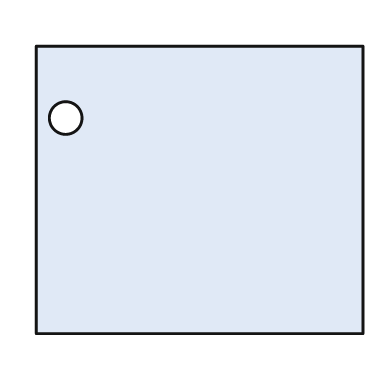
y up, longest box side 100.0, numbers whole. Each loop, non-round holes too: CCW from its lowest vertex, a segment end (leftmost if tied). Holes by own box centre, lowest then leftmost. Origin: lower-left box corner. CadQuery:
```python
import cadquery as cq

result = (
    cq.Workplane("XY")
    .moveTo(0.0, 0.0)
    .lineTo(100.0, 0.0)
    .lineTo(100.0, 88.0)
    .lineTo(0.0, 88.0)
    .close()
    .moveTo(9.0, 66.0)
    .circle(5.0)
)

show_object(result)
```